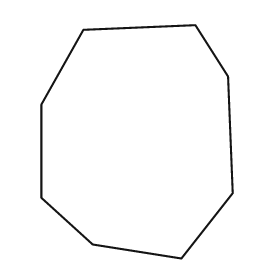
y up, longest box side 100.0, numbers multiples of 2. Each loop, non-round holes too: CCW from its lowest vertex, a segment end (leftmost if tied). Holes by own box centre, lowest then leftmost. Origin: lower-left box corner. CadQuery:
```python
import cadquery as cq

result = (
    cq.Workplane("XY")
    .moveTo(60.0, 0.0)
    .lineTo(82.0, 28.0)
    .lineTo(80.0, 78.0)
    .lineTo(66.0, 100.0)
    .lineTo(18.0, 98.0)
    .lineTo(0.0, 66.0)
    .lineTo(0.0, 26.0)
    .lineTo(22.0, 6.0)
    .close()
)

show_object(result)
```